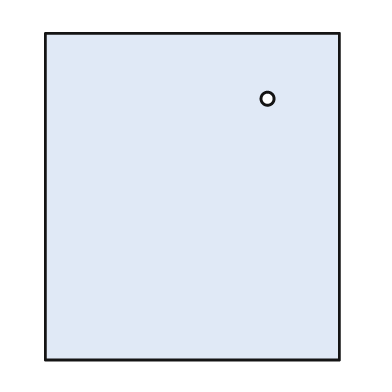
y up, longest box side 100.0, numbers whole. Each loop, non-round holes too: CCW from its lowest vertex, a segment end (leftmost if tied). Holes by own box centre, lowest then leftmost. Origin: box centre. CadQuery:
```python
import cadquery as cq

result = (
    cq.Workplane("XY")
    .moveTo(-45.0, -50.0)
    .lineTo(45.0, -50.0)
    .lineTo(45.0, 50.0)
    .lineTo(-45.0, 50.0)
    .close()
    .moveTo(23.0, 30.0)
    .circle(2.0)
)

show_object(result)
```